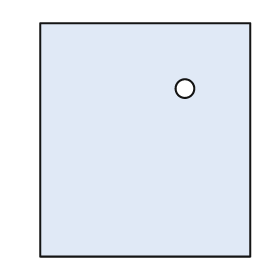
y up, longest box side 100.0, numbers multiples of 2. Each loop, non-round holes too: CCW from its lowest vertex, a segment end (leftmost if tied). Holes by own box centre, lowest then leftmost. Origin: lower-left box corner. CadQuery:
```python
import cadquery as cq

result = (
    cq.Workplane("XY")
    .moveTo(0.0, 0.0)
    .lineTo(90.0, 0.0)
    .lineTo(90.0, 100.0)
    .lineTo(0.0, 100.0)
    .close()
    .moveTo(62.0, 72.0)
    .circle(4.0)
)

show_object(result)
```